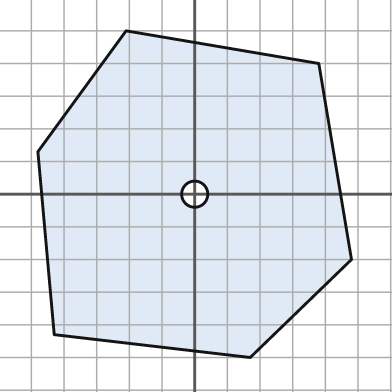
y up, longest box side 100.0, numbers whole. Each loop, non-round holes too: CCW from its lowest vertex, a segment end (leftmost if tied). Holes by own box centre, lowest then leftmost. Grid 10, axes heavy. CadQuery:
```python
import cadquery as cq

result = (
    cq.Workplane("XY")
    .moveTo(17.0, -50.0)
    .lineTo(48.0, -20.0)
    .lineTo(38.0, 40.0)
    .lineTo(-21.0, 50.0)
    .lineTo(-48.0, 13.0)
    .lineTo(-43.0, -43.0)
    .close()
    .moveTo(0.0, 0.0)
    .circle(4.0)
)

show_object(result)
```